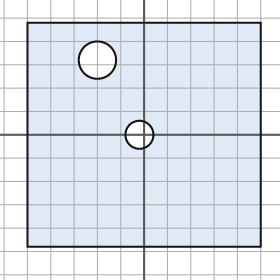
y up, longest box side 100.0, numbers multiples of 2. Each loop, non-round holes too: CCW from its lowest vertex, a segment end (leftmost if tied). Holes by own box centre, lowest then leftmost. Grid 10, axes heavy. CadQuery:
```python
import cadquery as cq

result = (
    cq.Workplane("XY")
    .moveTo(-50.0, -48.0)
    .lineTo(50.0, -48.0)
    .lineTo(50.0, 48.0)
    .lineTo(-50.0, 48.0)
    .close()
    .moveTo(-2.0, 0.0)
    .circle(6.0)
    .moveTo(-20.0, 32.0)
    .circle(8.0)
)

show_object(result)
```